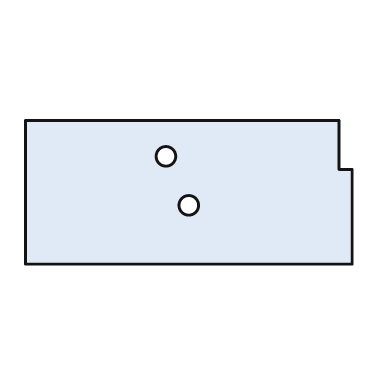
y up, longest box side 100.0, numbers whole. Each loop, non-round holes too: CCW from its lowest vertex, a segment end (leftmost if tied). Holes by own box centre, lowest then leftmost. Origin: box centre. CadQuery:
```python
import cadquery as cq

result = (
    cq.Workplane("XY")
    .moveTo(-50.0, -22.0)
    .lineTo(50.0, -22.0)
    .lineTo(50.0, 7.0)
    .lineTo(46.0, 7.0)
    .lineTo(46.0, 22.0)
    .lineTo(-50.0, 22.0)
    .close()
    .moveTo(0.0, -4.0)
    .circle(3.0)
    .moveTo(-7.0, 11.0)
    .circle(3.0)
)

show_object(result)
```